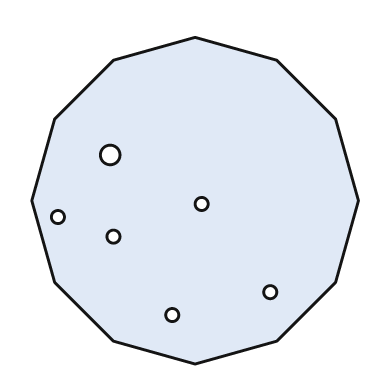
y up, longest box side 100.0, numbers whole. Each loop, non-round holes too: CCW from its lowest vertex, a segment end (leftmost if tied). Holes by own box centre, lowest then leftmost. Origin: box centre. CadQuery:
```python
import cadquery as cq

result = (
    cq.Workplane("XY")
    .moveTo(0.0, -50.0)
    .lineTo(25.0, -43.0)
    .lineTo(43.0, -25.0)
    .lineTo(50.0, 0.0)
    .lineTo(43.0, 25.0)
    .lineTo(25.0, 43.0)
    .lineTo(0.0, 50.0)
    .lineTo(-25.0, 43.0)
    .lineTo(-43.0, 25.0)
    .lineTo(-50.0, 0.0)
    .lineTo(-43.0, -25.0)
    .lineTo(-25.0, -43.0)
    .close()
    .moveTo(-7.0, -35.0)
    .circle(2.0)
    .moveTo(23.0, -28.0)
    .circle(2.0)
    .moveTo(-25.0, -11.0)
    .circle(2.0)
    .moveTo(-42.0, -5.0)
    .circle(2.0)
    .moveTo(2.0, -1.0)
    .circle(2.0)
    .moveTo(-26.0, 14.0)
    .circle(3.0)
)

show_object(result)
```